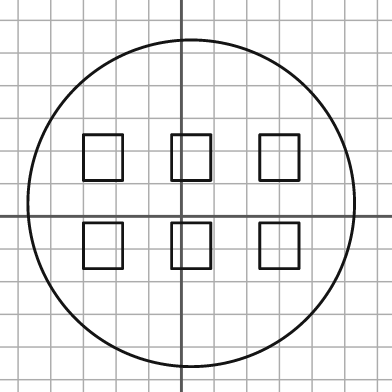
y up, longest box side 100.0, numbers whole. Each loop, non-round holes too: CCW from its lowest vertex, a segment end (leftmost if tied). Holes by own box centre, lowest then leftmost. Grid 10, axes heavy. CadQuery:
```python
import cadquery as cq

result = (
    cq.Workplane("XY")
    .moveTo(3.0, 4.0)
    .circle(50.0)
    .moveTo(-30.0, -16.0)
    .lineTo(-18.0, -16.0)
    .lineTo(-18.0, -2.0)
    .lineTo(-30.0, -2.0)
    .close()
    .moveTo(-3.0, -16.0)
    .lineTo(9.0, -16.0)
    .lineTo(9.0, -2.0)
    .lineTo(-3.0, -2.0)
    .close()
    .moveTo(24.0, -16.0)
    .lineTo(36.0, -16.0)
    .lineTo(36.0, -2.0)
    .lineTo(24.0, -2.0)
    .close()
    .moveTo(-30.0, 11.0)
    .lineTo(-18.0, 11.0)
    .lineTo(-18.0, 25.0)
    .lineTo(-30.0, 25.0)
    .close()
    .moveTo(-3.0, 11.0)
    .lineTo(9.0, 11.0)
    .lineTo(9.0, 25.0)
    .lineTo(-3.0, 25.0)
    .close()
    .moveTo(24.0, 11.0)
    .lineTo(36.0, 11.0)
    .lineTo(36.0, 25.0)
    .lineTo(24.0, 25.0)
    .close()
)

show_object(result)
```